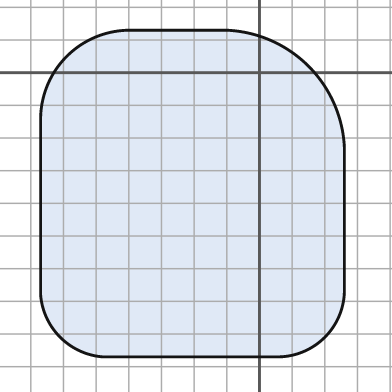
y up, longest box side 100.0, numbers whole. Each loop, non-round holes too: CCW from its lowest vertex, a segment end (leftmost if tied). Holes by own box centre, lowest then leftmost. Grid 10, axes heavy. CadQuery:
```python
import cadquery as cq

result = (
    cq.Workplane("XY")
    .moveTo(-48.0, -87.0)
    .lineTo(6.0, -87.0)
    .threePointArc((20.0, -81.0), (26.0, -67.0))
    .lineTo(26.0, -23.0)
    .threePointArc((15.0, 2.0), (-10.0, 13.0))
    .lineTo(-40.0, 13.0)
    .threePointArc((-59.0, 5.0), (-67.0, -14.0))
    .lineTo(-67.0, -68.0)
    .threePointArc((-61.0, -81.0), (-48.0, -87.0))
    .close()
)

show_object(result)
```